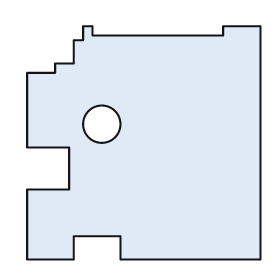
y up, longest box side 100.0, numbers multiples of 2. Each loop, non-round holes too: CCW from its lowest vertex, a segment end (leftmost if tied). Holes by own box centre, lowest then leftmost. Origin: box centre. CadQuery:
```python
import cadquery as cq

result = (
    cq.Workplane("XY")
    .moveTo(-50.0, -50.0)
    .lineTo(-30.0, -50.0)
    .lineTo(-30.0, -40.0)
    .lineTo(-10.0, -40.0)
    .lineTo(-10.0, -50.0)
    .lineTo(50.0, -50.0)
    .lineTo(50.0, 50.0)
    .lineTo(34.0, 50.0)
    .lineTo(34.0, 46.0)
    .lineTo(-22.0, 46.0)
    .lineTo(-22.0, 50.0)
    .lineTo(-26.0, 50.0)
    .lineTo(-26.0, 44.0)
    .lineTo(-30.0, 44.0)
    .lineTo(-30.0, 34.0)
    .lineTo(-38.0, 34.0)
    .lineTo(-38.0, 30.0)
    .lineTo(-50.0, 30.0)
    .lineTo(-50.0, -2.0)
    .lineTo(-32.0, -2.0)
    .lineTo(-32.0, -20.0)
    .lineTo(-50.0, -20.0)
    .close()
    .moveTo(-18.0, 8.0)
    .circle(8.0)
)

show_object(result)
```